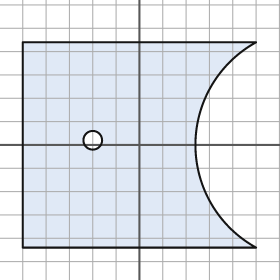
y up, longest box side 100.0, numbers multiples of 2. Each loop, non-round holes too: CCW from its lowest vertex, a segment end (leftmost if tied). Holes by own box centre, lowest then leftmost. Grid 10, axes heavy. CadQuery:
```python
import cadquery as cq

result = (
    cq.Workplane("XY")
    .moveTo(-50.0, -44.0)
    .lineTo(50.0, -44.0)
    .threePointArc((24.0, 0.0), (50.0, 44.0))
    .lineTo(-50.0, 44.0)
    .close()
    .moveTo(-20.0, 2.0)
    .circle(4.0)
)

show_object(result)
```